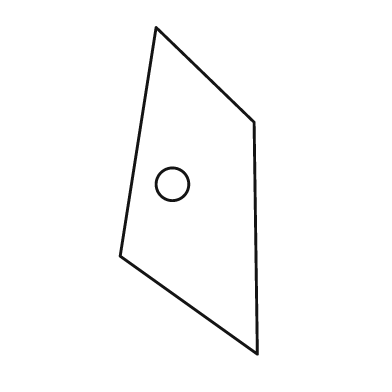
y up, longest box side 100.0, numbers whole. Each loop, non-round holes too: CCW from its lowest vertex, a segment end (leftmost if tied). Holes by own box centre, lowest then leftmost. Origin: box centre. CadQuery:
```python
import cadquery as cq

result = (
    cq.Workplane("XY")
    .moveTo(21.0, -50.0)
    .lineTo(20.0, 21.0)
    .lineTo(-10.0, 50.0)
    .lineTo(-21.0, -20.0)
    .close()
    .moveTo(-5.0, 2.0)
    .circle(5.0)
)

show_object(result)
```